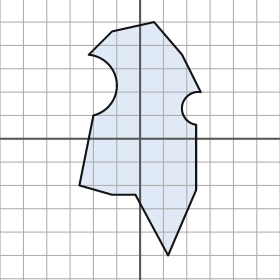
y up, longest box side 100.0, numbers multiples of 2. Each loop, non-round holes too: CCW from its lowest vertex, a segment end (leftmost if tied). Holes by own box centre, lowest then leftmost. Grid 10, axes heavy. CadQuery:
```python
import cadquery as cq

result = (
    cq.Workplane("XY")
    .moveTo(12.0, -50.0)
    .lineTo(24.0, -22.0)
    .lineTo(24.0, 6.0)
    .threePointArc((18.0, 14.0), (26.0, 20.0))
    .lineTo(18.0, 36.0)
    .lineTo(6.0, 50.0)
    .lineTo(-12.0, 46.0)
    .lineTo(-22.0, 36.0)
    .threePointArc((-10.0, 24.0), (-20.0, 10.0))
    .lineTo(-26.0, -20.0)
    .lineTo(-12.0, -24.0)
    .lineTo(-2.0, -24.0)
    .close()
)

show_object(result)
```